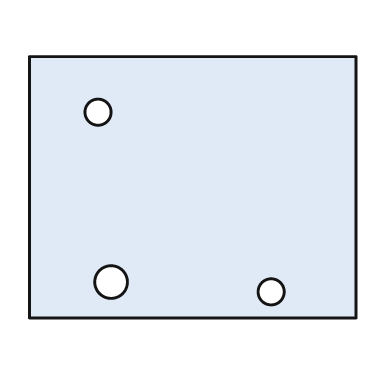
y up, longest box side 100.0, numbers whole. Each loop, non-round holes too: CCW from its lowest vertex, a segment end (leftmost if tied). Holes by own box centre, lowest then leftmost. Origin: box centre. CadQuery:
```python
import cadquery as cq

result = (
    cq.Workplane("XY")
    .moveTo(-50.0, -40.0)
    .lineTo(50.0, -40.0)
    .lineTo(50.0, 40.0)
    .lineTo(-50.0, 40.0)
    .close()
    .moveTo(24.0, -32.0)
    .circle(4.0)
    .moveTo(-25.0, -29.0)
    .circle(5.0)
    .moveTo(-29.0, 23.0)
    .circle(4.0)
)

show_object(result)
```